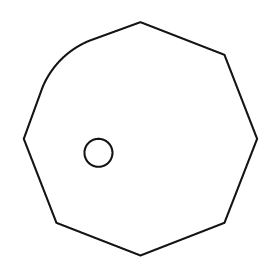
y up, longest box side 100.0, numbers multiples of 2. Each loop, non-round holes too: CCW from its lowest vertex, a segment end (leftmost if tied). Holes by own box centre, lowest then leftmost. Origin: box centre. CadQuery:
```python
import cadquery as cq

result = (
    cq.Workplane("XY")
    .moveTo(0.0, -50.0)
    .lineTo(36.0, -36.0)
    .lineTo(50.0, 0.0)
    .lineTo(36.0, 36.0)
    .lineTo(0.0, 50.0)
    .lineTo(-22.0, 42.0)
    .threePointArc((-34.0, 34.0), (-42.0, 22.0))
    .lineTo(-50.0, 0.0)
    .lineTo(-36.0, -36.0)
    .close()
    .moveTo(-18.0, -6.0)
    .circle(6.0)
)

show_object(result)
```